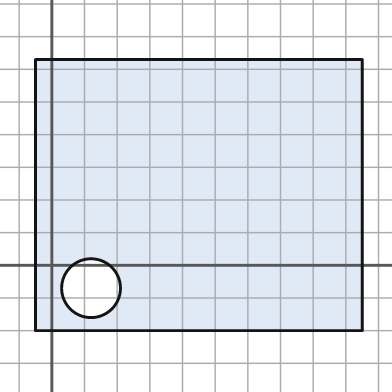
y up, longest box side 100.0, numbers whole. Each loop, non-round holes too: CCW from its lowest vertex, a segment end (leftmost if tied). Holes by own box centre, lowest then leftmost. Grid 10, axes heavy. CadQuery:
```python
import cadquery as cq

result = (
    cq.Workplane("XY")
    .moveTo(-5.0, -20.0)
    .lineTo(95.0, -20.0)
    .lineTo(95.0, 63.0)
    .lineTo(-5.0, 63.0)
    .close()
    .moveTo(12.0, -7.0)
    .circle(9.0)
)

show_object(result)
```